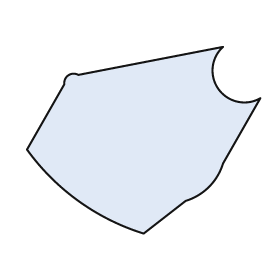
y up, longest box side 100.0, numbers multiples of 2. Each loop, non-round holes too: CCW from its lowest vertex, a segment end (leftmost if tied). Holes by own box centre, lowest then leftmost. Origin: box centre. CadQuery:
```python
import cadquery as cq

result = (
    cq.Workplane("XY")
    .moveTo(0.0, -40.0)
    .lineTo(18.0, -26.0)
    .threePointArc((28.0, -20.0), (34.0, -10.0))
    .lineTo(50.0, 18.0)
    .threePointArc((32.0, 22.0), (34.0, 40.0))
    .lineTo(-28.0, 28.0)
    .threePointArc((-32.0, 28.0), (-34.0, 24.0))
    .lineTo(-50.0, -4.0)
    .threePointArc((-28.0, -26.0), (0.0, -40.0))
    .close()
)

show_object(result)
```